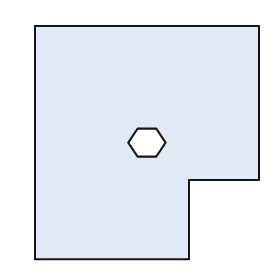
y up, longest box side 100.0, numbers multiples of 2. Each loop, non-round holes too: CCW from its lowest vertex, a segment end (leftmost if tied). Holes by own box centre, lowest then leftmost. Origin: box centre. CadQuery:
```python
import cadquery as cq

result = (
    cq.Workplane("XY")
    .moveTo(-48.0, -50.0)
    .lineTo(18.0, -50.0)
    .lineTo(18.0, -16.0)
    .lineTo(48.0, -16.0)
    .lineTo(48.0, 50.0)
    .lineTo(-48.0, 50.0)
    .close()
    .moveTo(-4.0, -6.0)
    .lineTo(4.0, -6.0)
    .lineTo(8.0, 0.0)
    .lineTo(4.0, 6.0)
    .lineTo(-4.0, 6.0)
    .lineTo(-8.0, 0.0)
    .close()
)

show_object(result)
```